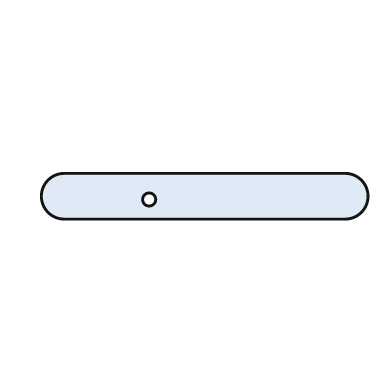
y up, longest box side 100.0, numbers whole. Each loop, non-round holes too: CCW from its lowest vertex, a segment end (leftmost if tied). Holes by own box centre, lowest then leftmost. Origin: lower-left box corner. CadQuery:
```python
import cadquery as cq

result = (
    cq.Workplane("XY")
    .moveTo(7.0, 0.0)
    .lineTo(93.0, 0.0)
    .threePointArc((100.0, 7.0), (93.0, 14.0))
    .lineTo(7.0, 14.0)
    .threePointArc((0.0, 7.0), (7.0, 0.0))
    .close()
    .moveTo(33.0, 6.0)
    .circle(2.0)
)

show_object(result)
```